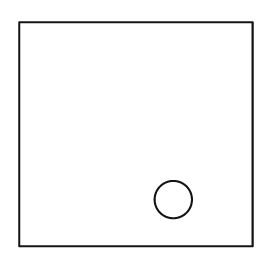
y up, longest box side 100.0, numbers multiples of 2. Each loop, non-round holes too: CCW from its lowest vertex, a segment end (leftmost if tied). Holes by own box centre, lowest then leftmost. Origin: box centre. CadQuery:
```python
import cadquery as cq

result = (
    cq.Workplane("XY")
    .moveTo(-50.0, -48.0)
    .lineTo(50.0, -48.0)
    .lineTo(50.0, 48.0)
    .lineTo(-50.0, 48.0)
    .close()
    .moveTo(16.0, -28.0)
    .circle(8.0)
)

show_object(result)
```